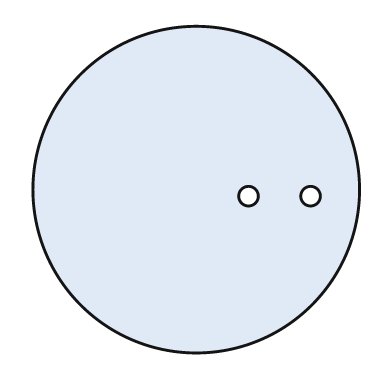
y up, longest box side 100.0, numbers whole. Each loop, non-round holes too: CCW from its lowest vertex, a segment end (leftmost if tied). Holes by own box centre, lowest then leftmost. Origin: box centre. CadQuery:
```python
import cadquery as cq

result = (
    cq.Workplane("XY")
    .moveTo(0.0, 0.0)
    .circle(50.0)
    .moveTo(16.0, -2.0)
    .circle(3.0)
    .moveTo(35.0, -2.0)
    .circle(3.0)
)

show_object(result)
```